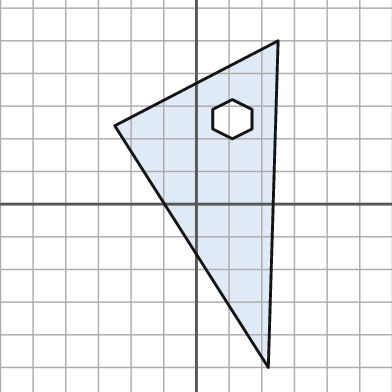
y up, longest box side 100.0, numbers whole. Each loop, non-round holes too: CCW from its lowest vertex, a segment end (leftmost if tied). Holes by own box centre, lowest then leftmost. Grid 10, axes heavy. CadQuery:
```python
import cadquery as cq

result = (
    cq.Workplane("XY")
    .moveTo(22.0, -50.0)
    .lineTo(25.0, 50.0)
    .lineTo(-25.0, 24.0)
    .close()
    .moveTo(11.0, 20.0)
    .lineTo(17.0, 23.0)
    .lineTo(17.0, 29.0)
    .lineTo(11.0, 32.0)
    .lineTo(5.0, 29.0)
    .lineTo(5.0, 23.0)
    .close()
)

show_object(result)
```